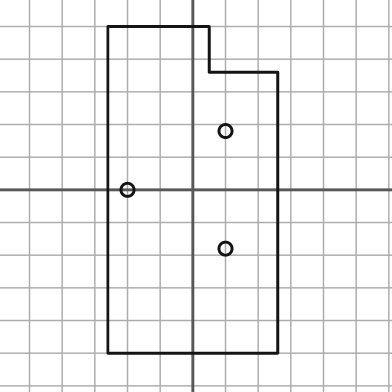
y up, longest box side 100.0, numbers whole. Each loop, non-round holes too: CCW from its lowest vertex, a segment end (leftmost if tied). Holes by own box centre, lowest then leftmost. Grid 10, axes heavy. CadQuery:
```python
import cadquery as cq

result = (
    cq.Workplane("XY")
    .moveTo(-26.0, -50.0)
    .lineTo(26.0, -50.0)
    .lineTo(26.0, 36.0)
    .lineTo(5.0, 36.0)
    .lineTo(5.0, 50.0)
    .lineTo(-26.0, 50.0)
    .close()
    .moveTo(10.0, -18.0)
    .circle(2.0)
    .moveTo(-20.0, 0.0)
    .circle(2.0)
    .moveTo(10.0, 18.0)
    .circle(2.0)
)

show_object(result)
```